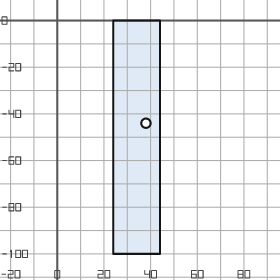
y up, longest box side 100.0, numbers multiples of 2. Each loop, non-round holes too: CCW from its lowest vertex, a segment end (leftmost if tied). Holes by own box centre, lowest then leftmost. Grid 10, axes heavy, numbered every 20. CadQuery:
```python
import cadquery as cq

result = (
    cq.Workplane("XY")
    .moveTo(24.0, -100.0)
    .lineTo(44.0, -100.0)
    .lineTo(44.0, 0.0)
    .lineTo(24.0, 0.0)
    .close()
    .moveTo(38.0, -44.0)
    .circle(2.0)
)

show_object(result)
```